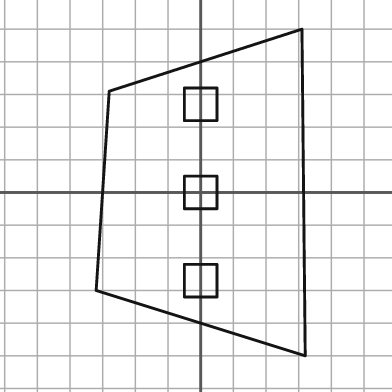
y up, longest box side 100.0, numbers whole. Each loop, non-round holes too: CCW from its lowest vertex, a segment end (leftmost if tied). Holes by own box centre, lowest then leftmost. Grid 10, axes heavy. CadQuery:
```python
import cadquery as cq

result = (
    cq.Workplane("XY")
    .moveTo(32.0, -50.0)
    .lineTo(31.0, 50.0)
    .lineTo(-28.0, 31.0)
    .lineTo(-32.0, -30.0)
    .close()
    .moveTo(-5.0, -32.0)
    .lineTo(5.0, -32.0)
    .lineTo(5.0, -22.0)
    .lineTo(-5.0, -22.0)
    .close()
    .moveTo(-5.0, -5.0)
    .lineTo(5.0, -5.0)
    .lineTo(5.0, 5.0)
    .lineTo(-5.0, 5.0)
    .close()
    .moveTo(-5.0, 22.0)
    .lineTo(5.0, 22.0)
    .lineTo(5.0, 32.0)
    .lineTo(-5.0, 32.0)
    .close()
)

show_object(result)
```